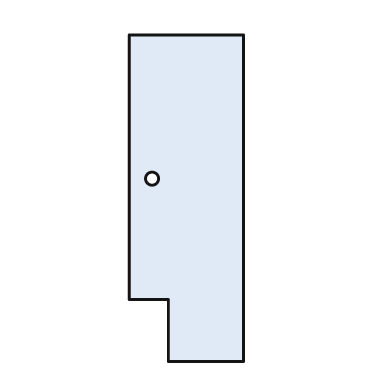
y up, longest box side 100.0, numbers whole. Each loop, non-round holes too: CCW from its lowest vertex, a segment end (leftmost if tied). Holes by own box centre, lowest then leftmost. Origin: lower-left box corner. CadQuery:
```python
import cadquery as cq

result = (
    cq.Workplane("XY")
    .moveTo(12.0, 0.0)
    .lineTo(35.0, 0.0)
    .lineTo(35.0, 100.0)
    .lineTo(0.0, 100.0)
    .lineTo(0.0, 19.0)
    .lineTo(12.0, 19.0)
    .close()
    .moveTo(7.0, 56.0)
    .circle(2.0)
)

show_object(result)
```